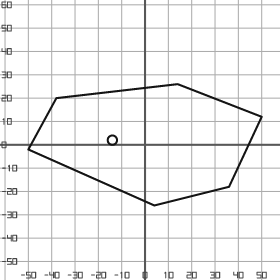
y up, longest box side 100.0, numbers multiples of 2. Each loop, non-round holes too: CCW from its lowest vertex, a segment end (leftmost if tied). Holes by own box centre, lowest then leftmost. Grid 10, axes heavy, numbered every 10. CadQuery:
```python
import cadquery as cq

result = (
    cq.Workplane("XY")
    .moveTo(4.0, -26.0)
    .lineTo(36.0, -18.0)
    .lineTo(50.0, 12.0)
    .lineTo(14.0, 26.0)
    .lineTo(-38.0, 20.0)
    .lineTo(-50.0, -2.0)
    .close()
    .moveTo(-14.0, 2.0)
    .circle(2.0)
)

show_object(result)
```